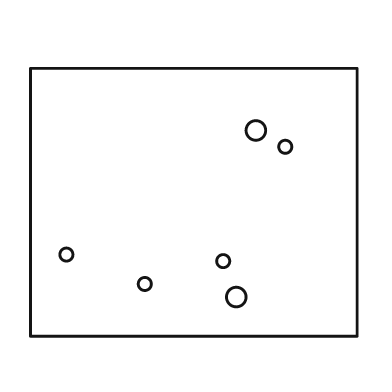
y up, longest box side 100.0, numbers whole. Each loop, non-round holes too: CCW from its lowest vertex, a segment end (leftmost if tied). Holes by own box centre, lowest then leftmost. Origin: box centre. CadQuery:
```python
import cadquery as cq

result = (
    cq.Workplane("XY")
    .moveTo(-50.0, -41.0)
    .lineTo(50.0, -41.0)
    .lineTo(50.0, 41.0)
    .lineTo(-50.0, 41.0)
    .close()
    .moveTo(13.0, -29.0)
    .circle(3.0)
    .moveTo(-15.0, -25.0)
    .circle(2.0)
    .moveTo(9.0, -18.0)
    .circle(2.0)
    .moveTo(-39.0, -16.0)
    .circle(2.0)
    .moveTo(28.0, 17.0)
    .circle(2.0)
    .moveTo(19.0, 22.0)
    .circle(3.0)
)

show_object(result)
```